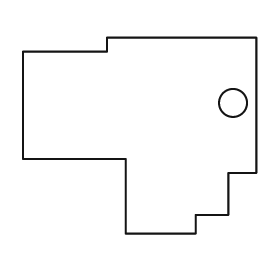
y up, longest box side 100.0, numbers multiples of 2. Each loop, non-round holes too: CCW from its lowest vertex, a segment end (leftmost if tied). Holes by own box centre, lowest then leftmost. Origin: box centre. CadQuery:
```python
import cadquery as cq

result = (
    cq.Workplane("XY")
    .moveTo(-6.0, -42.0)
    .lineTo(24.0, -42.0)
    .lineTo(24.0, -34.0)
    .lineTo(38.0, -34.0)
    .lineTo(38.0, -16.0)
    .lineTo(50.0, -16.0)
    .lineTo(50.0, 42.0)
    .lineTo(-14.0, 42.0)
    .lineTo(-14.0, 36.0)
    .lineTo(-50.0, 36.0)
    .lineTo(-50.0, -10.0)
    .lineTo(-6.0, -10.0)
    .close()
    .moveTo(40.0, 14.0)
    .circle(6.0)
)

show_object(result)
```